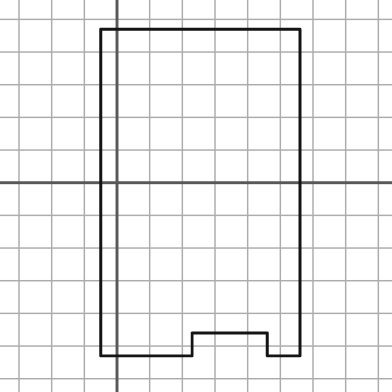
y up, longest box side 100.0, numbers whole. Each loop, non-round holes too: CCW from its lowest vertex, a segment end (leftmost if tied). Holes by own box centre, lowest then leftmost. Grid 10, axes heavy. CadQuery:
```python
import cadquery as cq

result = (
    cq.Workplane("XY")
    .moveTo(-5.0, -53.0)
    .lineTo(23.0, -53.0)
    .lineTo(23.0, -46.0)
    .lineTo(46.0, -46.0)
    .lineTo(46.0, -53.0)
    .lineTo(56.0, -53.0)
    .lineTo(56.0, 47.0)
    .lineTo(-5.0, 47.0)
    .close()
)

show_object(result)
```